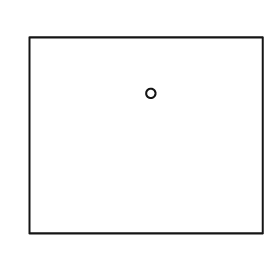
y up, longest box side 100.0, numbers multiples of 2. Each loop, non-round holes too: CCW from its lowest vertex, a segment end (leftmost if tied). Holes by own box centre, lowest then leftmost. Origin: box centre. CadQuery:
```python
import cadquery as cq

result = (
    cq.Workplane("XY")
    .moveTo(-50.0, -42.0)
    .lineTo(50.0, -42.0)
    .lineTo(50.0, 42.0)
    .lineTo(-50.0, 42.0)
    .close()
    .moveTo(2.0, 18.0)
    .circle(2.0)
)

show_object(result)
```